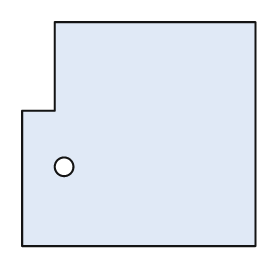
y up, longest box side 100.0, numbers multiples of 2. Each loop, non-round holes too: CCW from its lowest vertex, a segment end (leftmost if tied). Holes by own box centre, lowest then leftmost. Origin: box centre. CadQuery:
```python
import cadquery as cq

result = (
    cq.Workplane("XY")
    .moveTo(-50.0, -48.0)
    .lineTo(50.0, -48.0)
    .lineTo(50.0, 48.0)
    .lineTo(-36.0, 48.0)
    .lineTo(-36.0, 10.0)
    .lineTo(-50.0, 10.0)
    .close()
    .moveTo(-32.0, -14.0)
    .circle(4.0)
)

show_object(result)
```